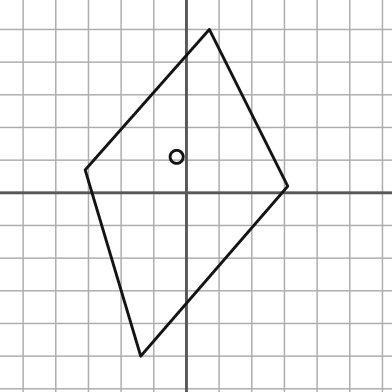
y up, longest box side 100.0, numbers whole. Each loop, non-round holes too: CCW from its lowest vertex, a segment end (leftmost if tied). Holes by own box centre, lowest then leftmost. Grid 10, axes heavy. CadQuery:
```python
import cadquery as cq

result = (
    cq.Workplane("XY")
    .moveTo(-14.0, -50.0)
    .lineTo(31.0, 2.0)
    .lineTo(7.0, 50.0)
    .lineTo(-31.0, 7.0)
    .close()
    .moveTo(-3.0, 11.0)
    .circle(2.0)
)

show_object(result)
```